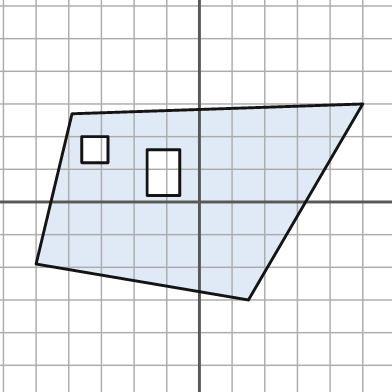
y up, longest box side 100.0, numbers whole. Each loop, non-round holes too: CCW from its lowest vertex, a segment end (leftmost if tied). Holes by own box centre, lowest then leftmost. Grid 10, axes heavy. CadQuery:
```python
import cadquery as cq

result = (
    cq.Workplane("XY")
    .moveTo(15.0, -30.0)
    .lineTo(50.0, 30.0)
    .lineTo(-39.0, 27.0)
    .lineTo(-50.0, -19.0)
    .close()
    .moveTo(-16.0, 2.0)
    .lineTo(-6.0, 2.0)
    .lineTo(-6.0, 16.0)
    .lineTo(-16.0, 16.0)
    .close()
    .moveTo(-36.0, 12.0)
    .lineTo(-28.0, 12.0)
    .lineTo(-28.0, 20.0)
    .lineTo(-36.0, 20.0)
    .close()
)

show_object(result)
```